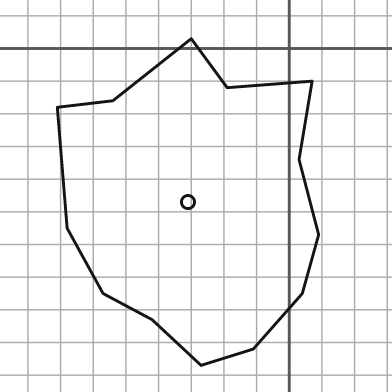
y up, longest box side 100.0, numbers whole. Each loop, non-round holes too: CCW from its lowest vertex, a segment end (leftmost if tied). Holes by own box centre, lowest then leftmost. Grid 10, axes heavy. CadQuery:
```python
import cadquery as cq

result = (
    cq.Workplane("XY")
    .moveTo(-27.0, -97.0)
    .lineTo(-11.0, -92.0)
    .lineTo(4.0, -75.0)
    .lineTo(9.0, -57.0)
    .lineTo(3.0, -34.0)
    .lineTo(7.0, -10.0)
    .lineTo(-19.0, -12.0)
    .lineTo(-30.0, 3.0)
    .lineTo(-54.0, -16.0)
    .lineTo(-71.0, -18.0)
    .lineTo(-68.0, -55.0)
    .lineTo(-57.0, -75.0)
    .lineTo(-42.0, -83.0)
    .close()
    .moveTo(-31.0, -47.0)
    .circle(2.0)
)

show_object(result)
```